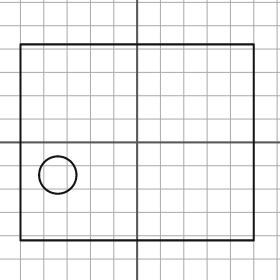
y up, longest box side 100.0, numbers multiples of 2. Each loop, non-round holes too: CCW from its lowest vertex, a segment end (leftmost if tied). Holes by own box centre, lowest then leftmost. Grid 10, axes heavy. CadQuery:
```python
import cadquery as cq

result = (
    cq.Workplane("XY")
    .moveTo(-50.0, -42.0)
    .lineTo(50.0, -42.0)
    .lineTo(50.0, 42.0)
    .lineTo(-50.0, 42.0)
    .close()
    .moveTo(-34.0, -14.0)
    .circle(8.0)
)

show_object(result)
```